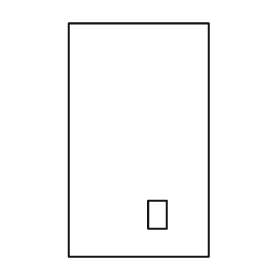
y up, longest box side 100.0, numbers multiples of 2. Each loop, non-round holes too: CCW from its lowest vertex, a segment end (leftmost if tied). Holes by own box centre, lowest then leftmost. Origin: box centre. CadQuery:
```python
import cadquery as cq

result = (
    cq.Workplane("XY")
    .moveTo(-30.0, -50.0)
    .lineTo(30.0, -50.0)
    .lineTo(30.0, 50.0)
    .lineTo(-30.0, 50.0)
    .close()
    .moveTo(4.0, -38.0)
    .lineTo(12.0, -38.0)
    .lineTo(12.0, -26.0)
    .lineTo(4.0, -26.0)
    .close()
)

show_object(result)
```